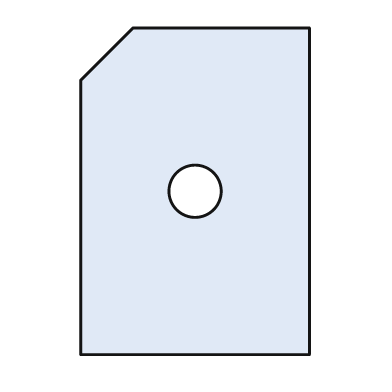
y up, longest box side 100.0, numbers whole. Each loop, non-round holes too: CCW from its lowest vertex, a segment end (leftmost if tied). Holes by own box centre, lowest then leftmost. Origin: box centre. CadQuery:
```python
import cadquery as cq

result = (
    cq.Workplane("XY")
    .moveTo(-35.0, -50.0)
    .lineTo(35.0, -50.0)
    .lineTo(35.0, 50.0)
    .lineTo(-19.0, 50.0)
    .lineTo(-35.0, 34.0)
    .close()
    .moveTo(0.0, 0.0)
    .circle(8.0)
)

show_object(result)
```